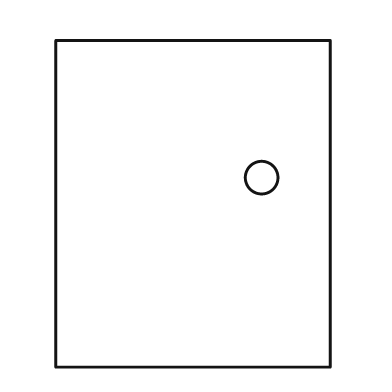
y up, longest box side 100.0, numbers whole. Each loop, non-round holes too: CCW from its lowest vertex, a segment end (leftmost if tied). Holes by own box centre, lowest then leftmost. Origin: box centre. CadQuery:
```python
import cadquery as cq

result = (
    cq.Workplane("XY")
    .moveTo(-42.0, -50.0)
    .lineTo(42.0, -50.0)
    .lineTo(42.0, 50.0)
    .lineTo(-42.0, 50.0)
    .close()
    .moveTo(21.0, 8.0)
    .circle(5.0)
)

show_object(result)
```